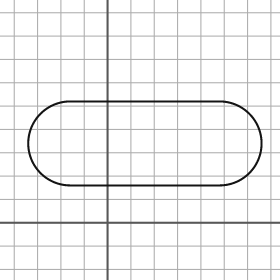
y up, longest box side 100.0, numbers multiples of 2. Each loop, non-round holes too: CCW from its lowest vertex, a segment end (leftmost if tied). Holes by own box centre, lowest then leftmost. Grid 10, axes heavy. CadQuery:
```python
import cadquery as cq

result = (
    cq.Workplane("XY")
    .moveTo(-16.0, 16.0)
    .lineTo(48.0, 16.0)
    .threePointArc((66.0, 34.0), (48.0, 52.0))
    .lineTo(-16.0, 52.0)
    .threePointArc((-34.0, 34.0), (-16.0, 16.0))
    .close()
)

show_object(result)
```